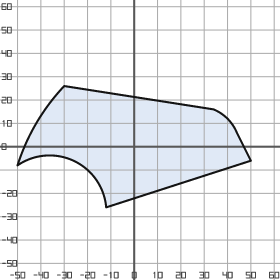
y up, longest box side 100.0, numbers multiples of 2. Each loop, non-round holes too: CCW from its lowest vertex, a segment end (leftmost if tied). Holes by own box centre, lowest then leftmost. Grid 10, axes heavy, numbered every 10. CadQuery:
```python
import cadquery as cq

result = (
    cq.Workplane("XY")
    .moveTo(-12.0, -26.0)
    .lineTo(50.0, -6.0)
    .lineTo(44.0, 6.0)
    .threePointArc((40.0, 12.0), (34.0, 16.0))
    .lineTo(-30.0, 26.0)
    .threePointArc((-42.0, 10.0), (-50.0, -8.0))
    .threePointArc((-26.0, -6.0), (-12.0, -26.0))
    .close()
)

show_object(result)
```